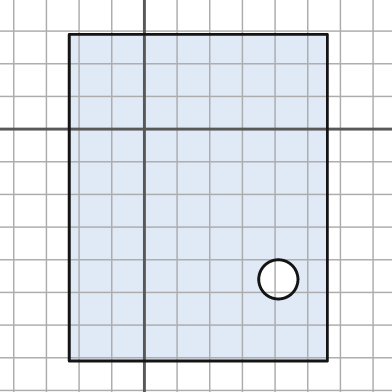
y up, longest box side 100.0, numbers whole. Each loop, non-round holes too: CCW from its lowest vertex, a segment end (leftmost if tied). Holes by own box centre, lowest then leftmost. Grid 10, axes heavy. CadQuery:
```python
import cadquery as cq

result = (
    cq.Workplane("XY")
    .moveTo(-23.0, -71.0)
    .lineTo(56.0, -71.0)
    .lineTo(56.0, 29.0)
    .lineTo(-23.0, 29.0)
    .close()
    .moveTo(41.0, -46.0)
    .circle(6.0)
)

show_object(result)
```